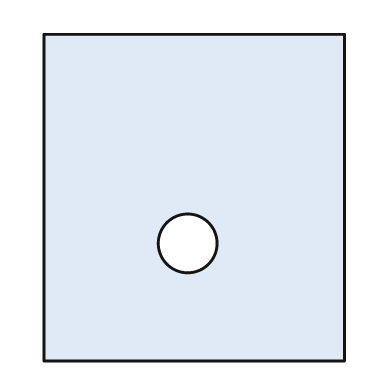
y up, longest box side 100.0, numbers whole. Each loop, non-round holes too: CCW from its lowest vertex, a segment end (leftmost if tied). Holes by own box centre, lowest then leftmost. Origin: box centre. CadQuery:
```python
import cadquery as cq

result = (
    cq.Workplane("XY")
    .moveTo(-46.0, -50.0)
    .lineTo(46.0, -50.0)
    .lineTo(46.0, 50.0)
    .lineTo(-46.0, 50.0)
    .close()
    .moveTo(-2.0, -14.0)
    .circle(9.0)
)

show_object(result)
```